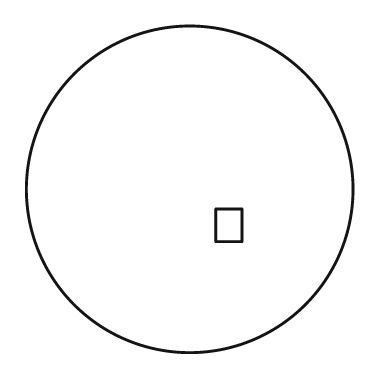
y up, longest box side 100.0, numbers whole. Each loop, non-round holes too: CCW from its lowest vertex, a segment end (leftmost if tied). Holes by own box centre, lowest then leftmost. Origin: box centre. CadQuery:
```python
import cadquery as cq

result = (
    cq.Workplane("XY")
    .moveTo(0.0, 0.0)
    .circle(50.0)
    .moveTo(8.0, -16.0)
    .lineTo(16.0, -16.0)
    .lineTo(16.0, -6.0)
    .lineTo(8.0, -6.0)
    .close()
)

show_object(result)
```